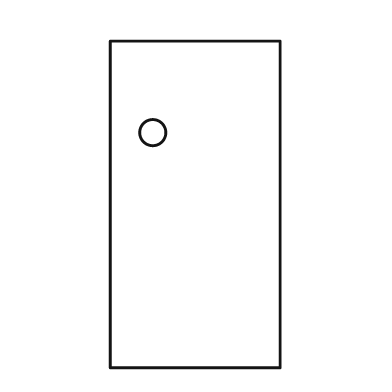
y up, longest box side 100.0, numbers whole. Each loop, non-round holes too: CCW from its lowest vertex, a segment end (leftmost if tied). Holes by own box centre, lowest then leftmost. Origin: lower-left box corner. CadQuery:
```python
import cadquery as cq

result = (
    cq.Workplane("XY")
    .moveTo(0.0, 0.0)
    .lineTo(52.0, 0.0)
    .lineTo(52.0, 100.0)
    .lineTo(0.0, 100.0)
    .close()
    .moveTo(13.0, 72.0)
    .circle(4.0)
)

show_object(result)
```